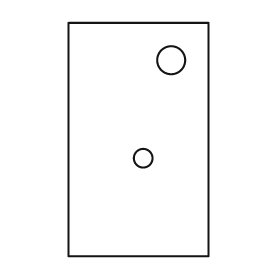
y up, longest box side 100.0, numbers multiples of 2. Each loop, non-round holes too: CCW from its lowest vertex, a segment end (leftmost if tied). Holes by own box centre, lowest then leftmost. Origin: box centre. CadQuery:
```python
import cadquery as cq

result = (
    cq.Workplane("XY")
    .moveTo(-30.0, -50.0)
    .lineTo(30.0, -50.0)
    .lineTo(30.0, 50.0)
    .lineTo(-30.0, 50.0)
    .close()
    .moveTo(2.0, -8.0)
    .circle(4.0)
    .moveTo(14.0, 34.0)
    .circle(6.0)
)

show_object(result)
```